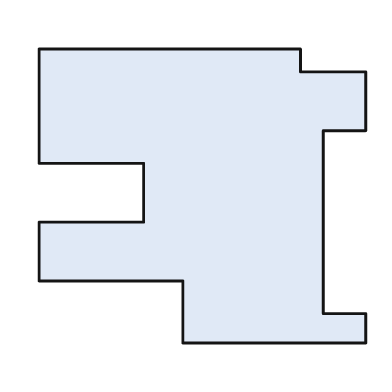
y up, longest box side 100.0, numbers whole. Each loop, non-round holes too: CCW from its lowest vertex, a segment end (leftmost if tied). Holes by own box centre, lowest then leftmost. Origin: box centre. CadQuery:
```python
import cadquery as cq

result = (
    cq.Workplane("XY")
    .moveTo(-6.0, -45.0)
    .lineTo(50.0, -45.0)
    .lineTo(50.0, -36.0)
    .lineTo(37.0, -36.0)
    .lineTo(37.0, 20.0)
    .lineTo(50.0, 20.0)
    .lineTo(50.0, 38.0)
    .lineTo(30.0, 38.0)
    .lineTo(30.0, 45.0)
    .lineTo(-50.0, 45.0)
    .lineTo(-50.0, 10.0)
    .lineTo(-18.0, 10.0)
    .lineTo(-18.0, -8.0)
    .lineTo(-50.0, -8.0)
    .lineTo(-50.0, -26.0)
    .lineTo(-6.0, -26.0)
    .close()
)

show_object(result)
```